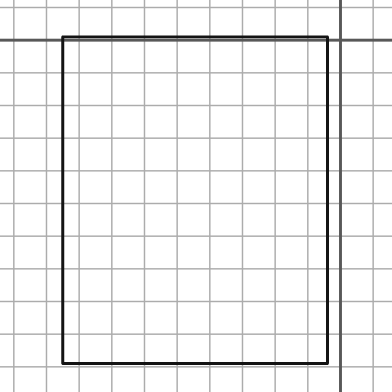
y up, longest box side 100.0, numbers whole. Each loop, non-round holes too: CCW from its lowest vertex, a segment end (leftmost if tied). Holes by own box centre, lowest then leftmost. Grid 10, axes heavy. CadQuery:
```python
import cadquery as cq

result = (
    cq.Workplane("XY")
    .moveTo(-85.0, -99.0)
    .lineTo(-4.0, -99.0)
    .lineTo(-4.0, 1.0)
    .lineTo(-85.0, 1.0)
    .close()
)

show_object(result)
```